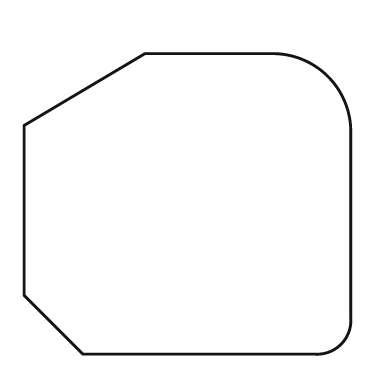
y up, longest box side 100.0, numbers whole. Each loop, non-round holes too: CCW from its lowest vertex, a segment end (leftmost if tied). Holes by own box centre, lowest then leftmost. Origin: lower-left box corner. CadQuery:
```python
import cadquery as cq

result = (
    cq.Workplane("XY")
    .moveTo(18.0, 0.0)
    .lineTo(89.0, 0.0)
    .threePointArc((97.0, 3.0), (100.0, 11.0))
    .lineTo(100.0, 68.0)
    .threePointArc((93.0, 85.0), (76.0, 92.0))
    .lineTo(37.0, 92.0)
    .lineTo(0.0, 70.0)
    .lineTo(0.0, 18.0)
    .close()
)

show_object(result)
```